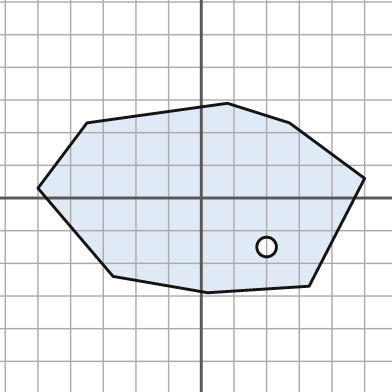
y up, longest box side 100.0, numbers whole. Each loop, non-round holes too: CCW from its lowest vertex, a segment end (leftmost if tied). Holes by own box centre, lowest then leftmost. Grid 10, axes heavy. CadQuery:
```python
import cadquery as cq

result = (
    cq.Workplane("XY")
    .moveTo(2.0, -29.0)
    .lineTo(33.0, -27.0)
    .lineTo(50.0, 6.0)
    .lineTo(27.0, 23.0)
    .lineTo(8.0, 29.0)
    .lineTo(-35.0, 23.0)
    .lineTo(-50.0, 3.0)
    .lineTo(-27.0, -24.0)
    .close()
    .moveTo(20.0, -15.0)
    .circle(3.0)
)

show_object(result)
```